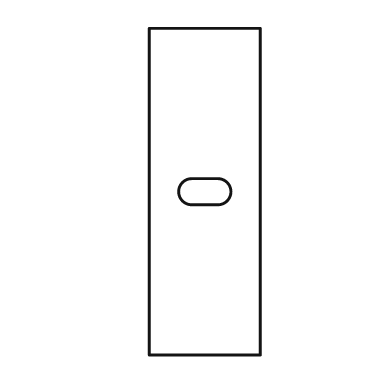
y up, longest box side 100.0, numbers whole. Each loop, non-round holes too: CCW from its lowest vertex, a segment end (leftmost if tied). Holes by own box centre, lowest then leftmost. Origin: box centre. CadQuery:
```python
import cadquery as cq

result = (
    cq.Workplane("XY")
    .moveTo(-17.0, -50.0)
    .lineTo(17.0, -50.0)
    .lineTo(17.0, 50.0)
    .lineTo(-17.0, 50.0)
    .close()
    .moveTo(-4.0, -4.0)
    .lineTo(4.0, -4.0)
    .threePointArc((8.0, 0.0), (4.0, 4.0))
    .lineTo(-4.0, 4.0)
    .threePointArc((-8.0, 0.0), (-4.0, -4.0))
    .close()
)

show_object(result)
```